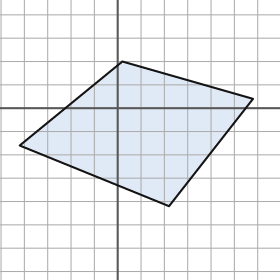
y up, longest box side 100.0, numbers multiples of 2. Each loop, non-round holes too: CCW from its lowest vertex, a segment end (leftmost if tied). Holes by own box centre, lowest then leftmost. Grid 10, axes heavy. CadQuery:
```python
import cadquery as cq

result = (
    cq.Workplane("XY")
    .moveTo(22.0, -42.0)
    .lineTo(58.0, 4.0)
    .lineTo(2.0, 20.0)
    .lineTo(-42.0, -16.0)
    .close()
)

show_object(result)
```